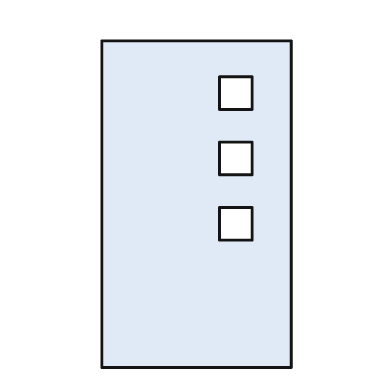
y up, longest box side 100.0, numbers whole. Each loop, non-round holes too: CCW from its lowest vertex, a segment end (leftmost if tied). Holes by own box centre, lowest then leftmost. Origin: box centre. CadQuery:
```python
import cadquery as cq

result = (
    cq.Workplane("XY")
    .moveTo(-29.0, -50.0)
    .lineTo(29.0, -50.0)
    .lineTo(29.0, 50.0)
    .lineTo(-29.0, 50.0)
    .close()
    .moveTo(7.0, -11.0)
    .lineTo(17.0, -11.0)
    .lineTo(17.0, -1.0)
    .lineTo(7.0, -1.0)
    .close()
    .moveTo(7.0, 9.0)
    .lineTo(17.0, 9.0)
    .lineTo(17.0, 19.0)
    .lineTo(7.0, 19.0)
    .close()
    .moveTo(7.0, 29.0)
    .lineTo(17.0, 29.0)
    .lineTo(17.0, 39.0)
    .lineTo(7.0, 39.0)
    .close()
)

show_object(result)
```